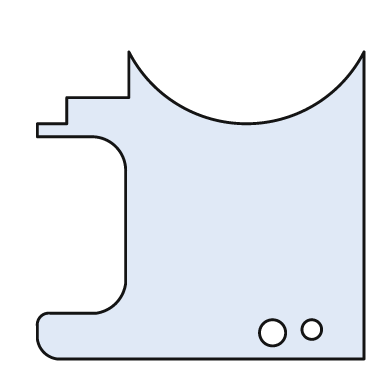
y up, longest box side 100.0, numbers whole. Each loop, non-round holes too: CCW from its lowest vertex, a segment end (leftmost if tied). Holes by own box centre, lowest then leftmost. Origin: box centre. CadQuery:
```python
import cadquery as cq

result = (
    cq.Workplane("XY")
    .moveTo(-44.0, -47.0)
    .lineTo(50.0, -47.0)
    .lineTo(50.0, 47.0)
    .threePointArc((14.0, 25.0), (-22.0, 47.0))
    .lineTo(-22.0, 33.0)
    .lineTo(-41.0, 33.0)
    .lineTo(-41.0, 25.0)
    .lineTo(-50.0, 25.0)
    .lineTo(-50.0, 21.0)
    .lineTo(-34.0, 21.0)
    .threePointArc((-26.0, 18.0), (-23.0, 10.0))
    .lineTo(-23.0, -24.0)
    .threePointArc((-26.0, -30.0), (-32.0, -33.0))
    .lineTo(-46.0, -33.0)
    .threePointArc((-49.0, -34.0), (-50.0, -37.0))
    .lineTo(-50.0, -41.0)
    .threePointArc((-48.0, -45.0), (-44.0, -47.0))
    .close()
    .moveTo(22.0, -39.0)
    .circle(4.0)
    .moveTo(34.0, -38.0)
    .circle(3.0)
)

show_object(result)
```